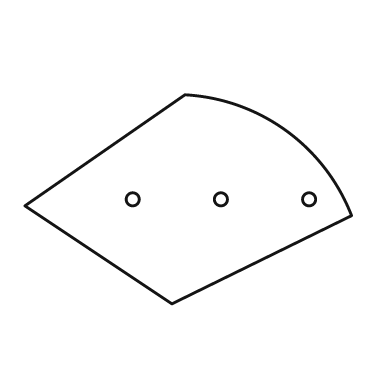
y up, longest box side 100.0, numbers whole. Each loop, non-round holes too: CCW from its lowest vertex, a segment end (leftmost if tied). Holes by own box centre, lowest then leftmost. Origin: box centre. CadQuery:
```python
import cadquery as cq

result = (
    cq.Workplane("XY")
    .moveTo(-5.0, -32.0)
    .lineTo(50.0, -5.0)
    .threePointArc((30.0, 21.0), (-1.0, 32.0))
    .lineTo(-50.0, -2.0)
    .close()
    .moveTo(-17.0, 0.0)
    .circle(2.0)
    .moveTo(10.0, 0.0)
    .circle(2.0)
    .moveTo(37.0, 0.0)
    .circle(2.0)
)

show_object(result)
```